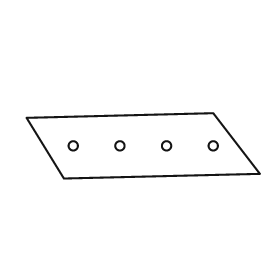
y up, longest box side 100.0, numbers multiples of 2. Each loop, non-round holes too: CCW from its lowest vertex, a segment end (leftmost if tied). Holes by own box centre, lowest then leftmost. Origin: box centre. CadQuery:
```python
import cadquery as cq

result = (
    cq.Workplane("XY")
    .moveTo(-34.0, -14.0)
    .lineTo(50.0, -12.0)
    .lineTo(30.0, 14.0)
    .lineTo(-50.0, 12.0)
    .close()
    .moveTo(-30.0, 0.0)
    .circle(2.0)
    .moveTo(-10.0, 0.0)
    .circle(2.0)
    .moveTo(10.0, 0.0)
    .circle(2.0)
    .moveTo(30.0, 0.0)
    .circle(2.0)
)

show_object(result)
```